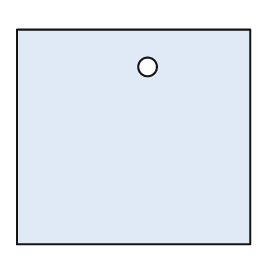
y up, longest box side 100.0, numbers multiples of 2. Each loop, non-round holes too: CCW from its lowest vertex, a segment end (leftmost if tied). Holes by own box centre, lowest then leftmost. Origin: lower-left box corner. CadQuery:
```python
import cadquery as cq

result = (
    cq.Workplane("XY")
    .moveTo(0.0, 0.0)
    .lineTo(100.0, 0.0)
    .lineTo(100.0, 92.0)
    .lineTo(0.0, 92.0)
    .close()
    .moveTo(56.0, 76.0)
    .circle(4.0)
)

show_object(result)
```